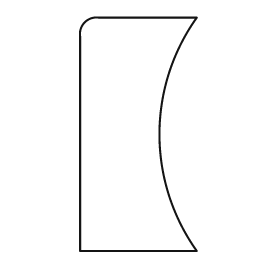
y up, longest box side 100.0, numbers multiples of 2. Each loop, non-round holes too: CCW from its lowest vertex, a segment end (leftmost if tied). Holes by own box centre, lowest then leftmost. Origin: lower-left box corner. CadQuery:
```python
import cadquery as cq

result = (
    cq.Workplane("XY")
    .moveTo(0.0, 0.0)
    .lineTo(50.0, 0.0)
    .threePointArc((34.0, 50.0), (50.0, 100.0))
    .lineTo(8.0, 100.0)
    .threePointArc((2.0, 98.0), (0.0, 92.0))
    .close()
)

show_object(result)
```